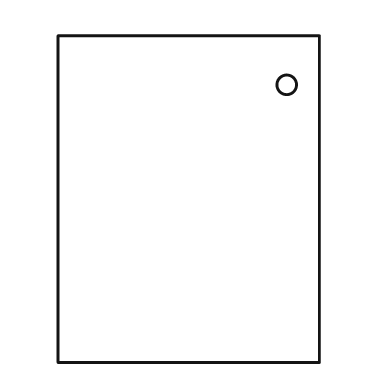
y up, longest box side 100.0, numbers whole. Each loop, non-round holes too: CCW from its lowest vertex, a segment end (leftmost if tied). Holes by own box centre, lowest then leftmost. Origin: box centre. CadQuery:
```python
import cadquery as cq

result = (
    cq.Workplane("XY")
    .moveTo(-40.0, -50.0)
    .lineTo(40.0, -50.0)
    .lineTo(40.0, 50.0)
    .lineTo(-40.0, 50.0)
    .close()
    .moveTo(30.0, 35.0)
    .circle(3.0)
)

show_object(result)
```